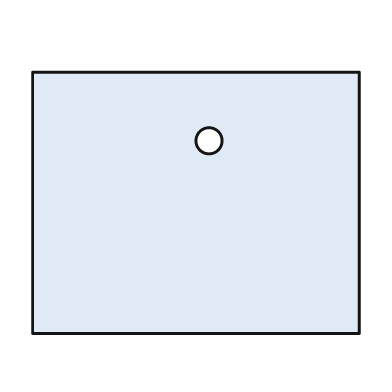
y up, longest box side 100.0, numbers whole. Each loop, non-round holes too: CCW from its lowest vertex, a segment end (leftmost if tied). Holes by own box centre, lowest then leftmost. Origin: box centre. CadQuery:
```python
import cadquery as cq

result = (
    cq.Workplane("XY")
    .moveTo(-50.0, -40.0)
    .lineTo(50.0, -40.0)
    .lineTo(50.0, 40.0)
    .lineTo(-50.0, 40.0)
    .close()
    .moveTo(4.0, 19.0)
    .circle(4.0)
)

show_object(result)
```